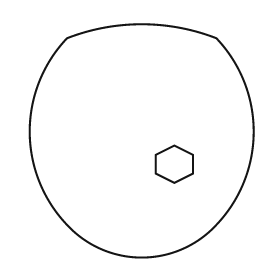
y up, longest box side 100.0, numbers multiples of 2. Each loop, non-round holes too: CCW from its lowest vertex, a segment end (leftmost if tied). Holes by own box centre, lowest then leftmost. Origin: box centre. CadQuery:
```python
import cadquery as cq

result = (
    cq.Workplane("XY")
    .moveTo(-32.0, -36.0)
    .threePointArc((0.0, -50.0), (32.0, -36.0))
    .threePointArc((48.0, 4.0), (32.0, 44.0))
    .threePointArc((0.0, 50.0), (-32.0, 44.0))
    .threePointArc((-48.0, 4.0), (-32.0, -36.0))
    .close()
    .moveTo(14.0, -18.0)
    .lineTo(22.0, -14.0)
    .lineTo(22.0, -6.0)
    .lineTo(14.0, -2.0)
    .lineTo(6.0, -6.0)
    .lineTo(6.0, -14.0)
    .close()
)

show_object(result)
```